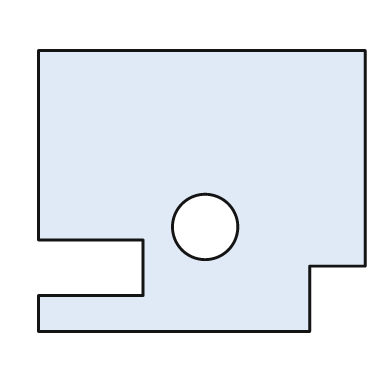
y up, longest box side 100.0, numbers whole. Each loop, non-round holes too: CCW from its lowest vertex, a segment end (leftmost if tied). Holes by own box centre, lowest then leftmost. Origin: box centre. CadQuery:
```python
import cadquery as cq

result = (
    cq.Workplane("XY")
    .moveTo(-50.0, -43.0)
    .lineTo(33.0, -43.0)
    .lineTo(33.0, -23.0)
    .lineTo(50.0, -23.0)
    .lineTo(50.0, 43.0)
    .lineTo(-50.0, 43.0)
    .lineTo(-50.0, -15.0)
    .lineTo(-18.0, -15.0)
    .lineTo(-18.0, -32.0)
    .lineTo(-50.0, -32.0)
    .close()
    .moveTo(1.0, -11.0)
    .circle(10.0)
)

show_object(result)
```